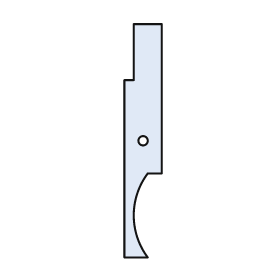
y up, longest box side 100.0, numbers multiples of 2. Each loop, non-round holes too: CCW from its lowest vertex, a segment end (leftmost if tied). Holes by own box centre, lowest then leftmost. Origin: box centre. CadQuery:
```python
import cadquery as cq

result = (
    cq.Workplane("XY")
    .moveTo(-8.0, -50.0)
    .lineTo(2.0, -50.0)
    .threePointArc((-4.0, -32.0), (2.0, -14.0))
    .lineTo(8.0, -14.0)
    .lineTo(8.0, 50.0)
    .lineTo(-4.0, 50.0)
    .lineTo(-4.0, 26.0)
    .lineTo(-8.0, 26.0)
    .close()
    .moveTo(0.0, 0.0)
    .circle(2.0)
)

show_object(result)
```